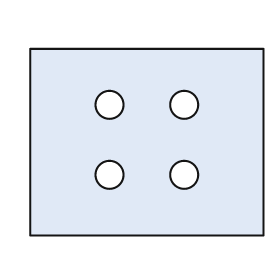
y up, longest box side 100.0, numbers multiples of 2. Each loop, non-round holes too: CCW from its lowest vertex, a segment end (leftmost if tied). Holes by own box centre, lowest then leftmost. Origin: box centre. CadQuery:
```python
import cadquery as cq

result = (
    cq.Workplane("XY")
    .moveTo(-50.0, -40.0)
    .lineTo(50.0, -40.0)
    .lineTo(50.0, 40.0)
    .lineTo(-50.0, 40.0)
    .close()
    .moveTo(-16.0, -14.0)
    .circle(6.0)
    .moveTo(16.0, -14.0)
    .circle(6.0)
    .moveTo(-16.0, 16.0)
    .circle(6.0)
    .moveTo(16.0, 16.0)
    .circle(6.0)
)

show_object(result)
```